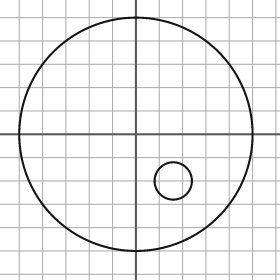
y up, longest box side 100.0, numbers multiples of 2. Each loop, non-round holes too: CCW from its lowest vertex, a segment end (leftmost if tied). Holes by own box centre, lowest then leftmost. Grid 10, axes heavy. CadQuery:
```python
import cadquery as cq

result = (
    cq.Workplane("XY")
    .moveTo(0.0, 0.0)
    .circle(50.0)
    .moveTo(16.0, -20.0)
    .circle(8.0)
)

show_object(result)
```